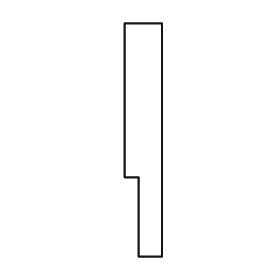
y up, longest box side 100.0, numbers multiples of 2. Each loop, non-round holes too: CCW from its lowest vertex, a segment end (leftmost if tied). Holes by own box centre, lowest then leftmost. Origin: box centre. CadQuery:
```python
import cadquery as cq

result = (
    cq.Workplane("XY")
    .moveTo(-2.0, -50.0)
    .lineTo(8.0, -50.0)
    .lineTo(8.0, 50.0)
    .lineTo(-8.0, 50.0)
    .lineTo(-8.0, -16.0)
    .lineTo(-2.0, -16.0)
    .close()
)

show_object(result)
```